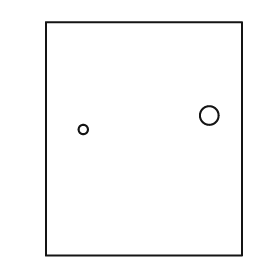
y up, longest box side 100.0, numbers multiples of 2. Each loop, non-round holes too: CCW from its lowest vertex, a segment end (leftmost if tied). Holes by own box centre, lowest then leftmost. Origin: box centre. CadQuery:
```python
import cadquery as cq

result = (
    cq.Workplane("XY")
    .moveTo(-42.0, -50.0)
    .lineTo(42.0, -50.0)
    .lineTo(42.0, 50.0)
    .lineTo(-42.0, 50.0)
    .close()
    .moveTo(-26.0, 4.0)
    .circle(2.0)
    .moveTo(28.0, 10.0)
    .circle(4.0)
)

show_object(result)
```